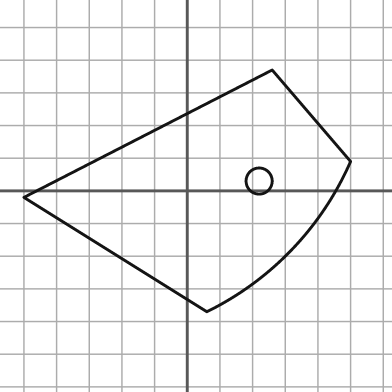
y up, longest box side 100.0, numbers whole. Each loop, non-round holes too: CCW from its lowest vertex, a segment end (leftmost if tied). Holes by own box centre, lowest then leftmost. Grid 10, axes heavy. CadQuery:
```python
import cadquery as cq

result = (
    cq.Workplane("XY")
    .moveTo(6.0, -37.0)
    .threePointArc((32.0, -18.0), (50.0, 9.0))
    .lineTo(26.0, 37.0)
    .lineTo(-50.0, -2.0)
    .close()
    .moveTo(22.0, 3.0)
    .circle(4.0)
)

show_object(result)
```